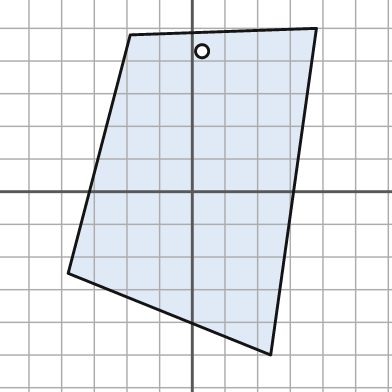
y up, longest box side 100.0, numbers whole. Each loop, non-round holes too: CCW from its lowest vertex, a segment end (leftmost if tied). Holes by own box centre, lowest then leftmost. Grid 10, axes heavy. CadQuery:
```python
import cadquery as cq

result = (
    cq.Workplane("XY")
    .moveTo(24.0, -50.0)
    .lineTo(38.0, 50.0)
    .lineTo(-19.0, 48.0)
    .lineTo(-38.0, -25.0)
    .close()
    .moveTo(3.0, 43.0)
    .circle(2.0)
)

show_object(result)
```